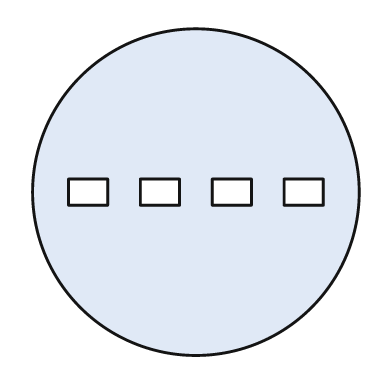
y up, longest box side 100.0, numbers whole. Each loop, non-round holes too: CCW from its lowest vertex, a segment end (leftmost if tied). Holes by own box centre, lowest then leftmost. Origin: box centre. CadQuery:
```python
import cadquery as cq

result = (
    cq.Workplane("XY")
    .moveTo(0.0, 0.0)
    .circle(50.0)
    .moveTo(-39.0, -4.0)
    .lineTo(-27.0, -4.0)
    .lineTo(-27.0, 4.0)
    .lineTo(-39.0, 4.0)
    .close()
    .moveTo(-17.0, -4.0)
    .lineTo(-5.0, -4.0)
    .lineTo(-5.0, 4.0)
    .lineTo(-17.0, 4.0)
    .close()
    .moveTo(5.0, -4.0)
    .lineTo(17.0, -4.0)
    .lineTo(17.0, 4.0)
    .lineTo(5.0, 4.0)
    .close()
    .moveTo(27.0, -4.0)
    .lineTo(39.0, -4.0)
    .lineTo(39.0, 4.0)
    .lineTo(27.0, 4.0)
    .close()
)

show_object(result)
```